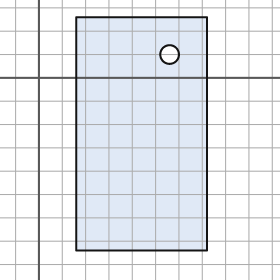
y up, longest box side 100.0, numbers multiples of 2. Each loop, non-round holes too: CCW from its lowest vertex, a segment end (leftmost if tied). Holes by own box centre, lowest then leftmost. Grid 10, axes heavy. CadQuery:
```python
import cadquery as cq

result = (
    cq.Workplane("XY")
    .moveTo(16.0, -74.0)
    .lineTo(72.0, -74.0)
    .lineTo(72.0, 26.0)
    .lineTo(16.0, 26.0)
    .close()
    .moveTo(56.0, 10.0)
    .circle(4.0)
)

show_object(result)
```